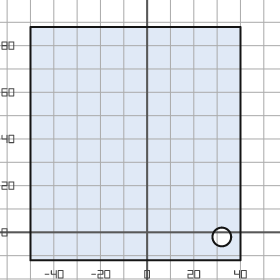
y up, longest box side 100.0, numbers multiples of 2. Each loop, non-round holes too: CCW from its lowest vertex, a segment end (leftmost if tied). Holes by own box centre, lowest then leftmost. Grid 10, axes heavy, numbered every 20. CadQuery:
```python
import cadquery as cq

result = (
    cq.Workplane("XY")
    .moveTo(-50.0, -12.0)
    .lineTo(40.0, -12.0)
    .lineTo(40.0, 88.0)
    .lineTo(-50.0, 88.0)
    .close()
    .moveTo(32.0, -2.0)
    .circle(4.0)
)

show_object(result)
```